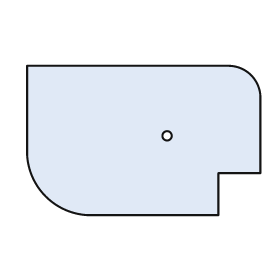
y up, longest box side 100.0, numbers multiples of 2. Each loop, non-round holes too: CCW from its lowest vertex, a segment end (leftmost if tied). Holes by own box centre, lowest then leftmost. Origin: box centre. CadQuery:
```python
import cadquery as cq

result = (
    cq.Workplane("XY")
    .moveTo(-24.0, -32.0)
    .lineTo(32.0, -32.0)
    .lineTo(32.0, -14.0)
    .lineTo(50.0, -14.0)
    .lineTo(50.0, 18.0)
    .threePointArc((46.0, 28.0), (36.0, 32.0))
    .lineTo(-50.0, 32.0)
    .lineTo(-50.0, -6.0)
    .threePointArc((-42.0, -24.0), (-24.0, -32.0))
    .close()
    .moveTo(10.0, 2.0)
    .circle(2.0)
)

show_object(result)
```